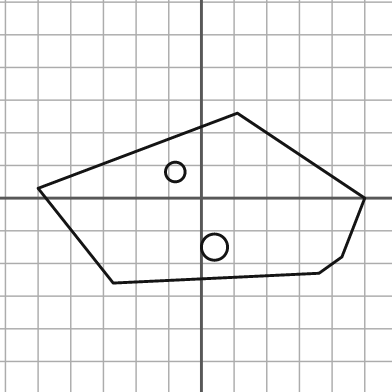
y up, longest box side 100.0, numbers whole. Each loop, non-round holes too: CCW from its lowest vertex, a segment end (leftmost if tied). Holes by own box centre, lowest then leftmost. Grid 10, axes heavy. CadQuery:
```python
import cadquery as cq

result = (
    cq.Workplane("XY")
    .moveTo(-27.0, -26.0)
    .lineTo(36.0, -23.0)
    .lineTo(43.0, -18.0)
    .lineTo(50.0, 0.0)
    .lineTo(11.0, 26.0)
    .lineTo(-50.0, 3.0)
    .close()
    .moveTo(4.0, -15.0)
    .circle(4.0)
    .moveTo(-8.0, 8.0)
    .circle(3.0)
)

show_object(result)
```